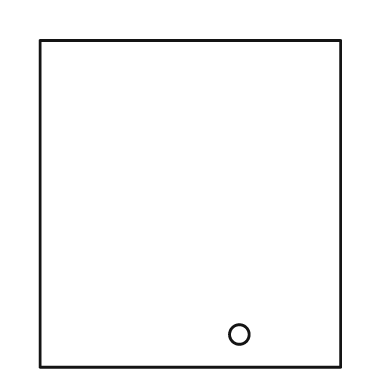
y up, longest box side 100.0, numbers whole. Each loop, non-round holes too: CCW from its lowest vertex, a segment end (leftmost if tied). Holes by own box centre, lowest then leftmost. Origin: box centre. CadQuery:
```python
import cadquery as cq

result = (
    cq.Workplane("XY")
    .moveTo(-46.0, -50.0)
    .lineTo(46.0, -50.0)
    .lineTo(46.0, 50.0)
    .lineTo(-46.0, 50.0)
    .close()
    .moveTo(15.0, -40.0)
    .circle(3.0)
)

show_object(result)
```